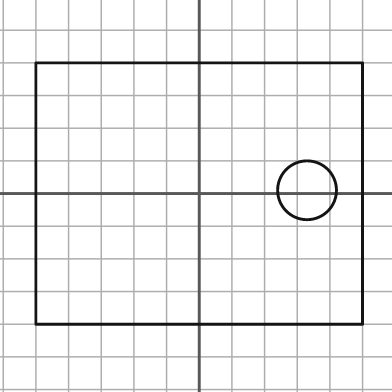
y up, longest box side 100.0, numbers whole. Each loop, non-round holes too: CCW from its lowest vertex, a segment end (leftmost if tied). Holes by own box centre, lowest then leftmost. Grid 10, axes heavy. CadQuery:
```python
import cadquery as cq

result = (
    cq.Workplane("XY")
    .moveTo(-50.0, -40.0)
    .lineTo(50.0, -40.0)
    .lineTo(50.0, 40.0)
    .lineTo(-50.0, 40.0)
    .close()
    .moveTo(33.0, 1.0)
    .circle(9.0)
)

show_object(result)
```